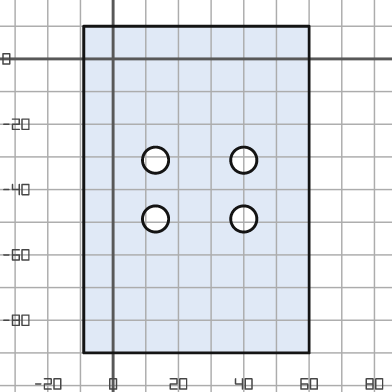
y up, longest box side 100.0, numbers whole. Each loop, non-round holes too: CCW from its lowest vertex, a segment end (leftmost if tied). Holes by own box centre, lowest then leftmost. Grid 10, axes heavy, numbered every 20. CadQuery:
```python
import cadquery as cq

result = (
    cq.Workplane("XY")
    .moveTo(-9.0, -90.0)
    .lineTo(60.0, -90.0)
    .lineTo(60.0, 10.0)
    .lineTo(-9.0, 10.0)
    .close()
    .moveTo(13.0, -49.0)
    .circle(4.0)
    .moveTo(40.0, -49.0)
    .circle(4.0)
    .moveTo(13.0, -31.0)
    .circle(4.0)
    .moveTo(40.0, -31.0)
    .circle(4.0)
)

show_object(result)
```